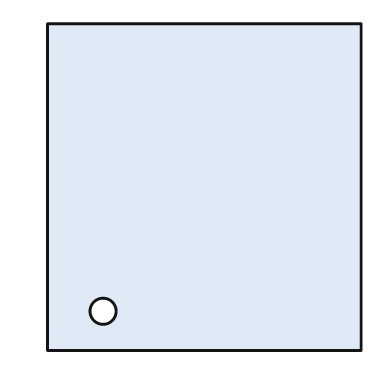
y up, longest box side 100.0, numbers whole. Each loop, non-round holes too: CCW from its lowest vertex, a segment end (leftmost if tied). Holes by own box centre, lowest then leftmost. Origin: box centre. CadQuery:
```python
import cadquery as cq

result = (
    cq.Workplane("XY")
    .moveTo(-48.0, -50.0)
    .lineTo(48.0, -50.0)
    .lineTo(48.0, 50.0)
    .lineTo(-48.0, 50.0)
    .close()
    .moveTo(-31.0, -38.0)
    .circle(4.0)
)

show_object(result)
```